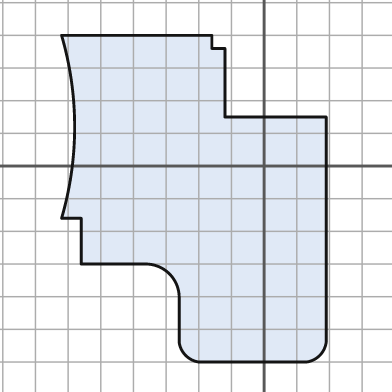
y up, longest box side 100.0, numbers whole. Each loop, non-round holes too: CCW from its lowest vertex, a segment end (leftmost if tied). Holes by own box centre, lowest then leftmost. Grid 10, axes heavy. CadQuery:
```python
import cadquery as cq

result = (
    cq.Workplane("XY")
    .moveTo(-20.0, -60.0)
    .lineTo(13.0, -60.0)
    .threePointArc((17.0, -58.0), (19.0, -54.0))
    .lineTo(19.0, 15.0)
    .lineTo(-12.0, 15.0)
    .lineTo(-12.0, 36.0)
    .lineTo(-16.0, 36.0)
    .lineTo(-16.0, 40.0)
    .lineTo(-62.0, 40.0)
    .threePointArc((-58.0, 12.0), (-62.0, -16.0))
    .lineTo(-56.0, -16.0)
    .lineTo(-56.0, -30.0)
    .lineTo(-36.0, -30.0)
    .threePointArc((-29.0, -33.0), (-26.0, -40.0))
    .lineTo(-26.0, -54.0)
    .threePointArc((-24.0, -58.0), (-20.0, -60.0))
    .close()
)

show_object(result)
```